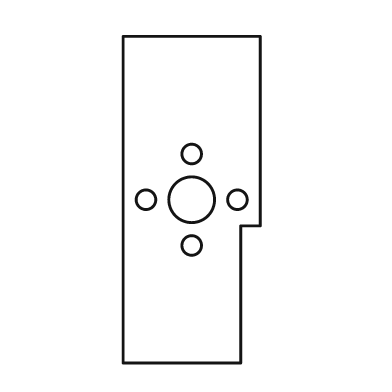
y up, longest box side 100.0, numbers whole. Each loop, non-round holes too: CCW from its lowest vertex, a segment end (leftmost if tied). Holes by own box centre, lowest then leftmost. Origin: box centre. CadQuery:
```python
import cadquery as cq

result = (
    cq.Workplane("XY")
    .moveTo(-21.0, -50.0)
    .lineTo(15.0, -50.0)
    .lineTo(15.0, -8.0)
    .lineTo(21.0, -8.0)
    .lineTo(21.0, 50.0)
    .lineTo(-21.0, 50.0)
    .close()
    .moveTo(0.0, -14.0)
    .circle(3.0)
    .moveTo(-14.0, 0.0)
    .circle(3.0)
    .moveTo(0.0, 0.0)
    .circle(7.0)
    .moveTo(14.0, 0.0)
    .circle(3.0)
    .moveTo(0.0, 14.0)
    .circle(3.0)
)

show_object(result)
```